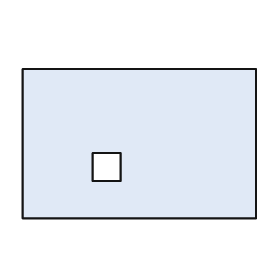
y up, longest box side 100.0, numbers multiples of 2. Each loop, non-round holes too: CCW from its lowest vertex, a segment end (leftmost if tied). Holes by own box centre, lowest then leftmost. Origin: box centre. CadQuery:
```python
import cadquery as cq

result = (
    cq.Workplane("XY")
    .moveTo(-50.0, -32.0)
    .lineTo(50.0, -32.0)
    .lineTo(50.0, 32.0)
    .lineTo(-50.0, 32.0)
    .close()
    .moveTo(-20.0, -16.0)
    .lineTo(-8.0, -16.0)
    .lineTo(-8.0, -4.0)
    .lineTo(-20.0, -4.0)
    .close()
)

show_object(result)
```